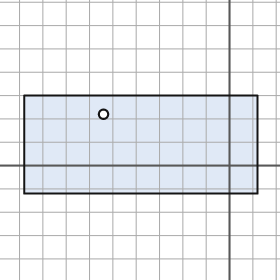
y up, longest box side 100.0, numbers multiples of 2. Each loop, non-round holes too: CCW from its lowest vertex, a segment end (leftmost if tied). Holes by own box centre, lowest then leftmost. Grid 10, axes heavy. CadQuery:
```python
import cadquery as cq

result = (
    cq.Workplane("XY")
    .moveTo(-88.0, -12.0)
    .lineTo(12.0, -12.0)
    .lineTo(12.0, 30.0)
    .lineTo(-88.0, 30.0)
    .close()
    .moveTo(-54.0, 22.0)
    .circle(2.0)
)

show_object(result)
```